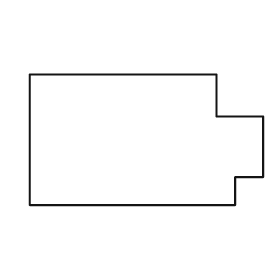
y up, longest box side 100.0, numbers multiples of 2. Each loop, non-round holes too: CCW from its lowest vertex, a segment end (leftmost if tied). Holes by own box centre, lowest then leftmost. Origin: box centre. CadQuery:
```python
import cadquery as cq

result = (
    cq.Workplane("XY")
    .moveTo(-50.0, -28.0)
    .lineTo(38.0, -28.0)
    .lineTo(38.0, -16.0)
    .lineTo(50.0, -16.0)
    .lineTo(50.0, 10.0)
    .lineTo(30.0, 10.0)
    .lineTo(30.0, 28.0)
    .lineTo(-50.0, 28.0)
    .close()
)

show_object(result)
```